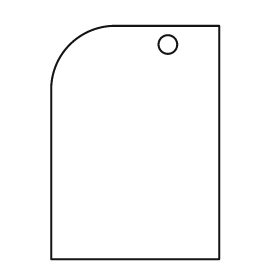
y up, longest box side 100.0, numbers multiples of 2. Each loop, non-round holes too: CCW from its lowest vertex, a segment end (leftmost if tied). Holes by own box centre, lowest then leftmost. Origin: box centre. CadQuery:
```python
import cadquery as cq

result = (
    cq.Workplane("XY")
    .moveTo(-36.0, -50.0)
    .lineTo(36.0, -50.0)
    .lineTo(36.0, 50.0)
    .lineTo(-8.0, 50.0)
    .threePointArc((-28.0, 42.0), (-36.0, 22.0))
    .close()
    .moveTo(14.0, 42.0)
    .circle(4.0)
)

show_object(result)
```